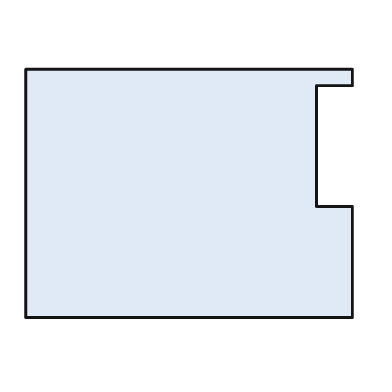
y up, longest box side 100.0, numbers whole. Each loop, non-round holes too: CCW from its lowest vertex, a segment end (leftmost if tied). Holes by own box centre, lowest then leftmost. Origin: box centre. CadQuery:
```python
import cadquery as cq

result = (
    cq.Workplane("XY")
    .moveTo(-50.0, -38.0)
    .lineTo(50.0, -38.0)
    .lineTo(50.0, -4.0)
    .lineTo(39.0, -4.0)
    .lineTo(39.0, 33.0)
    .lineTo(50.0, 33.0)
    .lineTo(50.0, 38.0)
    .lineTo(-50.0, 38.0)
    .close()
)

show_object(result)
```